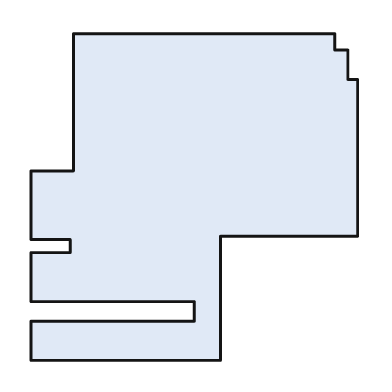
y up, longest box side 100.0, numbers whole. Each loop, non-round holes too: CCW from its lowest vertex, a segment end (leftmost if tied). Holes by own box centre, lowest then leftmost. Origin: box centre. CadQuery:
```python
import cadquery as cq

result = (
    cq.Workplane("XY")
    .moveTo(-50.0, -50.0)
    .lineTo(8.0, -50.0)
    .lineTo(8.0, -12.0)
    .lineTo(50.0, -12.0)
    .lineTo(50.0, 36.0)
    .lineTo(47.0, 36.0)
    .lineTo(47.0, 45.0)
    .lineTo(43.0, 45.0)
    .lineTo(43.0, 50.0)
    .lineTo(-37.0, 50.0)
    .lineTo(-37.0, 8.0)
    .lineTo(-50.0, 8.0)
    .lineTo(-50.0, -13.0)
    .lineTo(-38.0, -13.0)
    .lineTo(-38.0, -17.0)
    .lineTo(-50.0, -17.0)
    .lineTo(-50.0, -32.0)
    .lineTo(0.0, -32.0)
    .lineTo(0.0, -38.0)
    .lineTo(-50.0, -38.0)
    .close()
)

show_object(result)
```